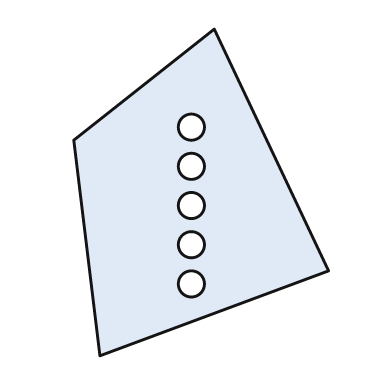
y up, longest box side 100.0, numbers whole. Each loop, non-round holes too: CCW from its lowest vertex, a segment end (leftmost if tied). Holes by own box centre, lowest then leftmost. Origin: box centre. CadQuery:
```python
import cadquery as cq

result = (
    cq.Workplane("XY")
    .moveTo(-31.0, -50.0)
    .lineTo(39.0, -24.0)
    .lineTo(4.0, 50.0)
    .lineTo(-39.0, 16.0)
    .close()
    .moveTo(-3.0, -28.0)
    .circle(4.0)
    .moveTo(-3.0, -16.0)
    .circle(4.0)
    .moveTo(-3.0, -4.0)
    .circle(4.0)
    .moveTo(-3.0, 8.0)
    .circle(4.0)
    .moveTo(-3.0, 20.0)
    .circle(4.0)
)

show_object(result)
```